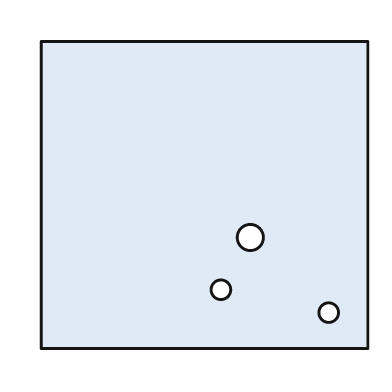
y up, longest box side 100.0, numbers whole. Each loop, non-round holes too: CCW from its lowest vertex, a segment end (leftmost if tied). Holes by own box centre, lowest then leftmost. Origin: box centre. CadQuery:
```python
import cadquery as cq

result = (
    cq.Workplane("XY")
    .moveTo(-50.0, -47.0)
    .lineTo(50.0, -47.0)
    .lineTo(50.0, 47.0)
    .lineTo(-50.0, 47.0)
    .close()
    .moveTo(38.0, -36.0)
    .circle(3.0)
    .moveTo(5.0, -29.0)
    .circle(3.0)
    .moveTo(14.0, -13.0)
    .circle(4.0)
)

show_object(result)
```